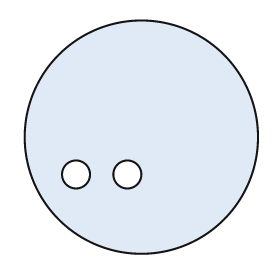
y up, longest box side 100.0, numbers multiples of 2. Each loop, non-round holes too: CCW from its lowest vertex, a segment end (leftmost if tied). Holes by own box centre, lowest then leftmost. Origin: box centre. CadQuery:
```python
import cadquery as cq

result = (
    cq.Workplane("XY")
    .moveTo(0.0, 0.0)
    .circle(50.0)
    .moveTo(-28.0, -16.0)
    .circle(6.0)
    .moveTo(-6.0, -16.0)
    .circle(6.0)
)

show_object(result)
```